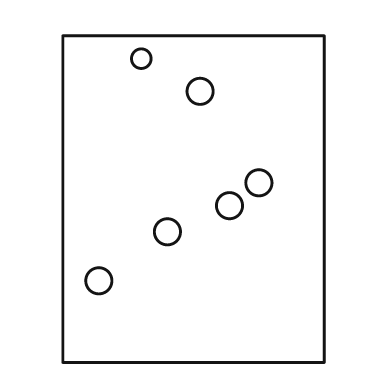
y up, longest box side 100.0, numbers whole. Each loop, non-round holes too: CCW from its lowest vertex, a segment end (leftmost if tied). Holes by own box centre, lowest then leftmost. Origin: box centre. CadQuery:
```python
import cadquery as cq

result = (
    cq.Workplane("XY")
    .moveTo(-40.0, -50.0)
    .lineTo(40.0, -50.0)
    .lineTo(40.0, 50.0)
    .lineTo(-40.0, 50.0)
    .close()
    .moveTo(-29.0, -25.0)
    .circle(4.0)
    .moveTo(-8.0, -10.0)
    .circle(4.0)
    .moveTo(11.0, -2.0)
    .circle(4.0)
    .moveTo(20.0, 5.0)
    .circle(4.0)
    .moveTo(2.0, 33.0)
    .circle(4.0)
    .moveTo(-16.0, 43.0)
    .circle(3.0)
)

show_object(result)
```